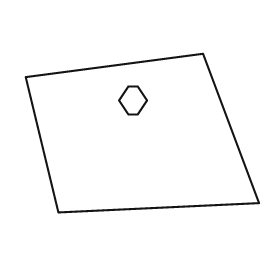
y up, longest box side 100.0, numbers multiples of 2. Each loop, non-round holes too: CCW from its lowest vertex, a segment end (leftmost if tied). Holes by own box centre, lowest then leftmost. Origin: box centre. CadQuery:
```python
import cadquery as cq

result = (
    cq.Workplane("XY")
    .moveTo(-36.0, -34.0)
    .lineTo(50.0, -30.0)
    .lineTo(26.0, 34.0)
    .lineTo(-50.0, 24.0)
    .close()
    .moveTo(-6.0, 8.0)
    .lineTo(-2.0, 8.0)
    .lineTo(2.0, 14.0)
    .lineTo(-2.0, 20.0)
    .lineTo(-6.0, 20.0)
    .lineTo(-10.0, 14.0)
    .close()
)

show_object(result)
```